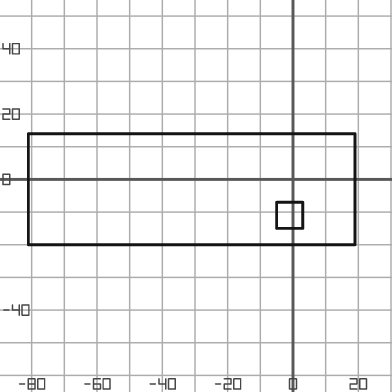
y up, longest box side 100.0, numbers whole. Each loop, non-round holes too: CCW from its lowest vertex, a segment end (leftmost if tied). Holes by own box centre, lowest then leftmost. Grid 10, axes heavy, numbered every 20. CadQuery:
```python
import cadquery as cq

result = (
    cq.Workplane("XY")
    .moveTo(-81.0, -20.0)
    .lineTo(19.0, -20.0)
    .lineTo(19.0, 14.0)
    .lineTo(-81.0, 14.0)
    .close()
    .moveTo(-5.0, -15.0)
    .lineTo(3.0, -15.0)
    .lineTo(3.0, -7.0)
    .lineTo(-5.0, -7.0)
    .close()
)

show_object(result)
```